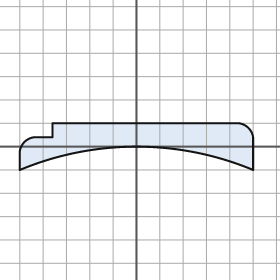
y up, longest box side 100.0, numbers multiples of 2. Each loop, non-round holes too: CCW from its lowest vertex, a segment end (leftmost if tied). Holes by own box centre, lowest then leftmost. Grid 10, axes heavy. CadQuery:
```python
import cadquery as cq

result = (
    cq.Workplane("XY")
    .moveTo(-50.0, -10.0)
    .threePointArc((0.0, 0.0), (50.0, -10.0))
    .lineTo(50.0, 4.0)
    .threePointArc((48.0, 8.0), (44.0, 10.0))
    .lineTo(-36.0, 10.0)
    .lineTo(-36.0, 4.0)
    .lineTo(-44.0, 4.0)
    .threePointArc((-48.0, 2.0), (-50.0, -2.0))
    .close()
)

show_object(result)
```